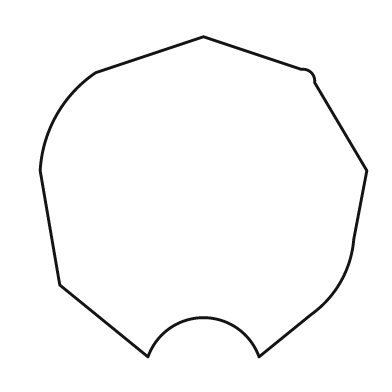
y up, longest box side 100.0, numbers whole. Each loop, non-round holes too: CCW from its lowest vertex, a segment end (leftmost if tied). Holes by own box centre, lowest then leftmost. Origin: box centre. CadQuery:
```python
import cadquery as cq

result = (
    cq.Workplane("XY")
    .moveTo(-17.0, -49.0)
    .threePointArc((0.0, -37.0), (17.0, -49.0))
    .lineTo(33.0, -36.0)
    .threePointArc((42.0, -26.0), (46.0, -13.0))
    .lineTo(50.0, 8.0)
    .lineTo(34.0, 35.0)
    .threePointArc((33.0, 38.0), (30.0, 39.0))
    .lineTo(0.0, 49.0)
    .lineTo(-33.0, 38.0)
    .threePointArc((-45.0, 25.0), (-50.0, 8.0))
    .lineTo(-44.0, -27.0)
    .close()
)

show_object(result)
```